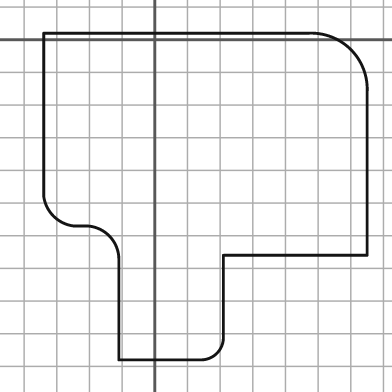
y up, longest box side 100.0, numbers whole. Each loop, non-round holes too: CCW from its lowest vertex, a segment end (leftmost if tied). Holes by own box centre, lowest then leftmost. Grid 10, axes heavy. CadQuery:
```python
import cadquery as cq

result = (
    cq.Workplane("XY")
    .moveTo(-11.0, -98.0)
    .lineTo(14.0, -98.0)
    .threePointArc((19.0, -96.0), (21.0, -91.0))
    .lineTo(21.0, -66.0)
    .lineTo(65.0, -66.0)
    .lineTo(65.0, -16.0)
    .threePointArc((60.0, -3.0), (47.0, 2.0))
    .lineTo(-34.0, 2.0)
    .lineTo(-34.0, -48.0)
    .threePointArc((-31.0, -54.0), (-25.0, -57.0))
    .lineTo(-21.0, -57.0)
    .threePointArc((-14.0, -60.0), (-11.0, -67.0))
    .close()
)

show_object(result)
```